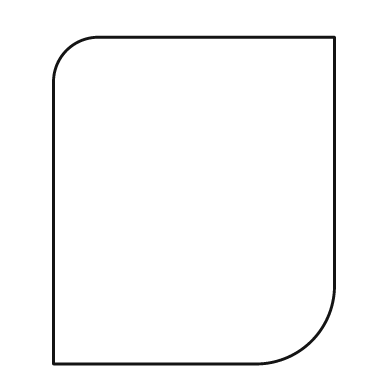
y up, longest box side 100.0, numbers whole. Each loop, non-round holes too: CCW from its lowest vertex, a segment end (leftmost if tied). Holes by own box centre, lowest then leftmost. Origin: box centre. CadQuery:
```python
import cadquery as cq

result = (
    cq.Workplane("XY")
    .moveTo(-43.0, -50.0)
    .lineTo(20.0, -50.0)
    .threePointArc((36.0, -43.0), (43.0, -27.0))
    .lineTo(43.0, 50.0)
    .lineTo(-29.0, 50.0)
    .threePointArc((-39.0, 46.0), (-43.0, 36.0))
    .close()
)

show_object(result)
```